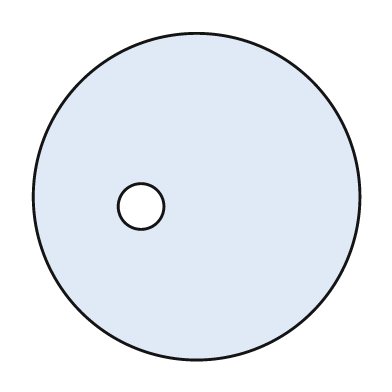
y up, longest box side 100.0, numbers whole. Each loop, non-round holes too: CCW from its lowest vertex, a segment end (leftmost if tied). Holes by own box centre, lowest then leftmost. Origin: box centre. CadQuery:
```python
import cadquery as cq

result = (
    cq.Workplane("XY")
    .moveTo(0.0, 0.0)
    .circle(50.0)
    .moveTo(-17.0, -3.0)
    .circle(7.0)
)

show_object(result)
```